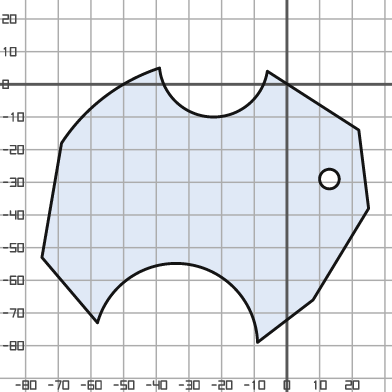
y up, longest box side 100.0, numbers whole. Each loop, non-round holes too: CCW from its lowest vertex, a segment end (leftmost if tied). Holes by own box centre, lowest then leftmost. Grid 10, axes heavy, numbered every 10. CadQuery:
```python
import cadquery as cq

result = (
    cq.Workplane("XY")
    .moveTo(-9.0, -79.0)
    .lineTo(8.0, -66.0)
    .lineTo(25.0, -38.0)
    .lineTo(22.0, -14.0)
    .lineTo(-6.0, 4.0)
    .threePointArc((-23.0, -10.0), (-39.0, 5.0))
    .threePointArc((-56.0, -4.0), (-69.0, -18.0))
    .lineTo(-75.0, -53.0)
    .lineTo(-58.0, -73.0)
    .threePointArc((-31.0, -55.0), (-9.0, -79.0))
    .close()
    .moveTo(13.0, -29.0)
    .circle(3.0)
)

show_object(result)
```